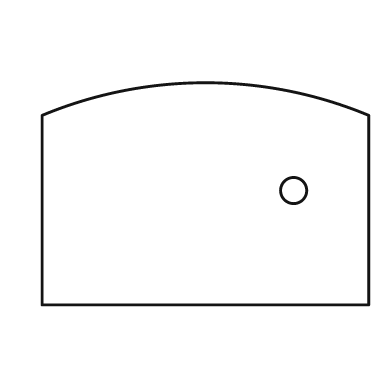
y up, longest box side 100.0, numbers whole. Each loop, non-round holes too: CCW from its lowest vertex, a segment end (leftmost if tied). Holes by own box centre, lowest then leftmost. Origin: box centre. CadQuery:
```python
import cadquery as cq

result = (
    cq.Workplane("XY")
    .moveTo(-50.0, -34.0)
    .lineTo(50.0, -34.0)
    .lineTo(50.0, 24.0)
    .threePointArc((0.0, 34.0), (-50.0, 24.0))
    .close()
    .moveTo(27.0, 1.0)
    .circle(4.0)
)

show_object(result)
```